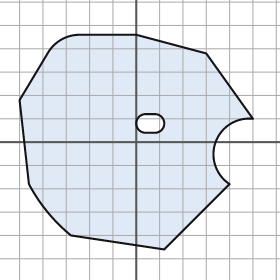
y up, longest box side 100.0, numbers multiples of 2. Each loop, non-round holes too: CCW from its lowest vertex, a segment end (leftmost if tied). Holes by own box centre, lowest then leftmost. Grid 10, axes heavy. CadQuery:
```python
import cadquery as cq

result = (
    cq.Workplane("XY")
    .moveTo(12.0, -46.0)
    .lineTo(40.0, -18.0)
    .threePointArc((34.0, 0.0), (50.0, 10.0))
    .lineTo(30.0, 38.0)
    .lineTo(0.0, 46.0)
    .lineTo(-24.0, 46.0)
    .threePointArc((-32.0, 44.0), (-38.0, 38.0))
    .lineTo(-50.0, 18.0)
    .lineTo(-46.0, -18.0)
    .threePointArc((-38.0, -30.0), (-28.0, -40.0))
    .close()
    .moveTo(4.0, 4.0)
    .lineTo(8.0, 4.0)
    .threePointArc((12.0, 8.0), (8.0, 12.0))
    .lineTo(4.0, 12.0)
    .threePointArc((0.0, 8.0), (4.0, 4.0))
    .close()
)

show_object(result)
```